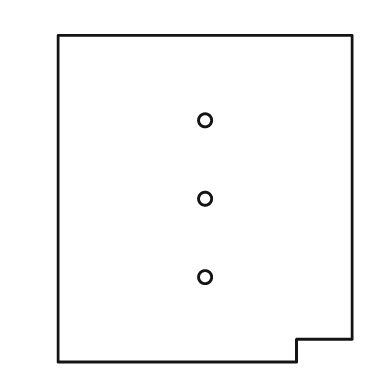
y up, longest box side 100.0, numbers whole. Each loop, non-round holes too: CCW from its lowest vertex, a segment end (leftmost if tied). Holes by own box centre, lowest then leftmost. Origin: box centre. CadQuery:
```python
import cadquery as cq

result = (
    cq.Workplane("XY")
    .moveTo(-45.0, -50.0)
    .lineTo(28.0, -50.0)
    .lineTo(28.0, -43.0)
    .lineTo(45.0, -43.0)
    .lineTo(45.0, 50.0)
    .lineTo(-45.0, 50.0)
    .close()
    .moveTo(0.0, -24.0)
    .circle(2.0)
    .moveTo(0.0, 0.0)
    .circle(2.0)
    .moveTo(0.0, 24.0)
    .circle(2.0)
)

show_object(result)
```